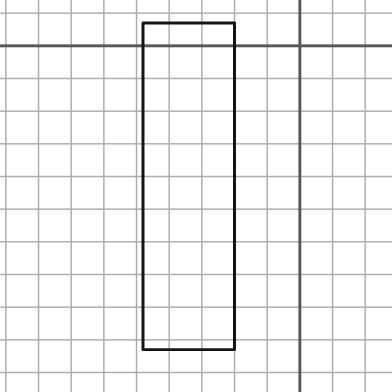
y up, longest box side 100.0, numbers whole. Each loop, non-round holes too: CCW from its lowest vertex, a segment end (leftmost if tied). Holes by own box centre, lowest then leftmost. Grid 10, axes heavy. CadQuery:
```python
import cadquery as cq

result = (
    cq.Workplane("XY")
    .moveTo(-48.0, -93.0)
    .lineTo(-20.0, -93.0)
    .lineTo(-20.0, 7.0)
    .lineTo(-48.0, 7.0)
    .close()
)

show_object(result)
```